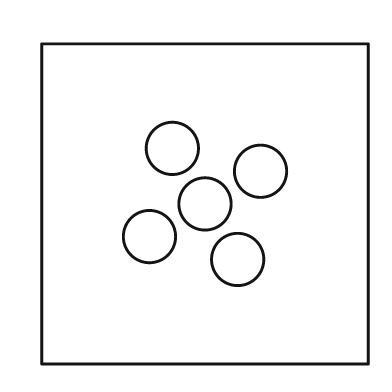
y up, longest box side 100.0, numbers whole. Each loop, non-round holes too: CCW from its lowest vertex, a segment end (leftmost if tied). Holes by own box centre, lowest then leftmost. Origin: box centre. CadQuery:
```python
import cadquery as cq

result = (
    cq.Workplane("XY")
    .moveTo(-50.0, -49.0)
    .lineTo(50.0, -49.0)
    .lineTo(50.0, 49.0)
    .lineTo(-50.0, 49.0)
    .close()
    .moveTo(10.0, -17.0)
    .circle(8.0)
    .moveTo(-17.0, -10.0)
    .circle(8.0)
    .moveTo(0.0, 0.0)
    .circle(8.0)
    .moveTo(17.0, 10.0)
    .circle(8.0)
    .moveTo(-10.0, 17.0)
    .circle(8.0)
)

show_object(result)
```